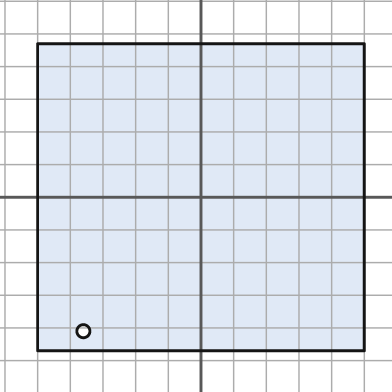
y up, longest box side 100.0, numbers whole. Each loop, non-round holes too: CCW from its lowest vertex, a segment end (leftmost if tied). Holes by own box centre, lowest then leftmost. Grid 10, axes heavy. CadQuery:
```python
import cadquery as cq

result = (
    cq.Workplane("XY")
    .moveTo(-50.0, -47.0)
    .lineTo(50.0, -47.0)
    .lineTo(50.0, 47.0)
    .lineTo(-50.0, 47.0)
    .close()
    .moveTo(-36.0, -41.0)
    .circle(2.0)
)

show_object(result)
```